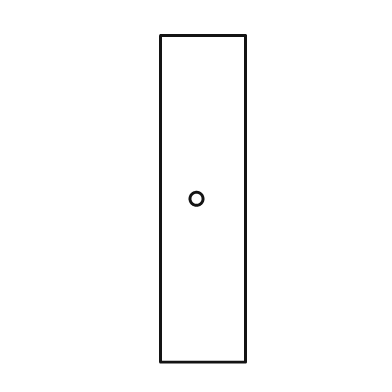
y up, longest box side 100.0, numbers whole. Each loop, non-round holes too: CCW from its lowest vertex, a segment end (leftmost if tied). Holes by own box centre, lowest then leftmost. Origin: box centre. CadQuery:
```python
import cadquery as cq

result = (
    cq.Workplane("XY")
    .moveTo(-13.0, -50.0)
    .lineTo(13.0, -50.0)
    .lineTo(13.0, 50.0)
    .lineTo(-13.0, 50.0)
    .close()
    .moveTo(-2.0, 0.0)
    .circle(2.0)
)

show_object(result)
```